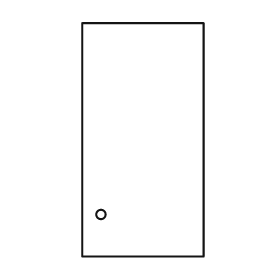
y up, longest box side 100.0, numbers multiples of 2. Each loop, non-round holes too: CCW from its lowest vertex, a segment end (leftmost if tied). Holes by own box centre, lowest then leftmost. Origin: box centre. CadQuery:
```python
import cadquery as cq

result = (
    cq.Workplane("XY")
    .moveTo(-26.0, -50.0)
    .lineTo(26.0, -50.0)
    .lineTo(26.0, 50.0)
    .lineTo(-26.0, 50.0)
    .close()
    .moveTo(-18.0, -32.0)
    .circle(2.0)
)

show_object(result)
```